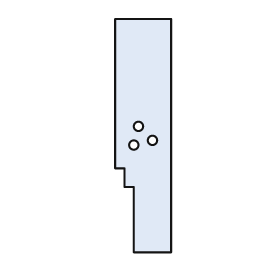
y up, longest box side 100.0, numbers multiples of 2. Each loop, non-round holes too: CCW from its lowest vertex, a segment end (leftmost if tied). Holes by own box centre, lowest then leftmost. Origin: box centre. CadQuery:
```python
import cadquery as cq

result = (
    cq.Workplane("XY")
    .moveTo(-4.0, -50.0)
    .lineTo(12.0, -50.0)
    .lineTo(12.0, 50.0)
    .lineTo(-12.0, 50.0)
    .lineTo(-12.0, -14.0)
    .lineTo(-8.0, -14.0)
    .lineTo(-8.0, -22.0)
    .lineTo(-4.0, -22.0)
    .close()
    .moveTo(-4.0, -4.0)
    .circle(2.0)
    .moveTo(4.0, -2.0)
    .circle(2.0)
    .moveTo(-2.0, 4.0)
    .circle(2.0)
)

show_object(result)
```